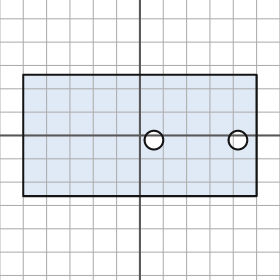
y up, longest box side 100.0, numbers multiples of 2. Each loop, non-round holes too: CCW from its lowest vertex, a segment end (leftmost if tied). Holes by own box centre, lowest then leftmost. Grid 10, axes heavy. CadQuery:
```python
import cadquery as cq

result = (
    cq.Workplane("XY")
    .moveTo(-50.0, -26.0)
    .lineTo(50.0, -26.0)
    .lineTo(50.0, 26.0)
    .lineTo(-50.0, 26.0)
    .close()
    .moveTo(6.0, -2.0)
    .circle(4.0)
    .moveTo(42.0, -2.0)
    .circle(4.0)
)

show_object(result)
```